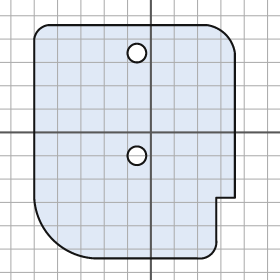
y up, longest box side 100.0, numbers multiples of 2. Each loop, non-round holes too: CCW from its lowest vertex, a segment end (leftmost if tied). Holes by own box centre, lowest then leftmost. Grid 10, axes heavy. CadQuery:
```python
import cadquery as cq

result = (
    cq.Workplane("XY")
    .moveTo(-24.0, -54.0)
    .lineTo(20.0, -54.0)
    .threePointArc((26.0, -52.0), (28.0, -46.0))
    .lineTo(28.0, -28.0)
    .lineTo(36.0, -28.0)
    .lineTo(36.0, 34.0)
    .threePointArc((32.0, 42.0), (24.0, 46.0))
    .lineTo(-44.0, 46.0)
    .threePointArc((-48.0, 44.0), (-50.0, 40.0))
    .lineTo(-50.0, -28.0)
    .threePointArc((-42.0, -46.0), (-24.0, -54.0))
    .close()
    .moveTo(-6.0, -10.0)
    .circle(4.0)
    .moveTo(-6.0, 34.0)
    .circle(4.0)
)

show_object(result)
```